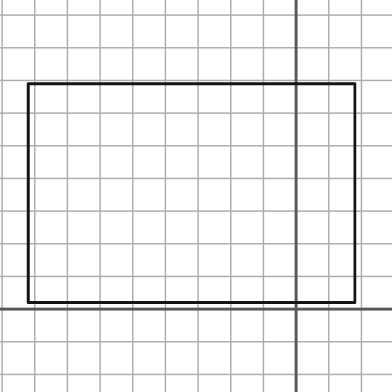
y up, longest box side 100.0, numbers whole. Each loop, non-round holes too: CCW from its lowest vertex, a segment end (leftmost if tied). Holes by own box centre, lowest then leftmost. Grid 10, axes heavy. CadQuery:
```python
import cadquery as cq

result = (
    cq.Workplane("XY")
    .moveTo(-82.0, 2.0)
    .lineTo(18.0, 2.0)
    .lineTo(18.0, 69.0)
    .lineTo(-82.0, 69.0)
    .close()
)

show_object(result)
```